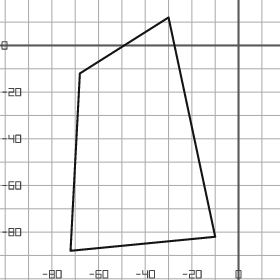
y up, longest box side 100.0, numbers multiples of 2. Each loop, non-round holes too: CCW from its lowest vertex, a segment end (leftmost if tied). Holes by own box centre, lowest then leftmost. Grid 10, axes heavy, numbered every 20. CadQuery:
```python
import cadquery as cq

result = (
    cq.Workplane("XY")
    .moveTo(-72.0, -88.0)
    .lineTo(-10.0, -82.0)
    .lineTo(-30.0, 12.0)
    .lineTo(-68.0, -12.0)
    .close()
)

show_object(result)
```